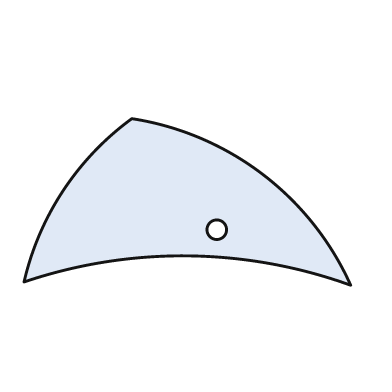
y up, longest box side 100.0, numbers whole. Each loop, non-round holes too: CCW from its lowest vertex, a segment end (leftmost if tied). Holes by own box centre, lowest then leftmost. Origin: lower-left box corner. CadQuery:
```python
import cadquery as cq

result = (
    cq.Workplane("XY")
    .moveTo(100.0, 0.0)
    .threePointArc((73.0, 34.0), (33.0, 51.0))
    .threePointArc((12.0, 29.0), (0.0, 1.0))
    .threePointArc((50.0, 9.0), (100.0, 0.0))
    .close()
    .moveTo(59.0, 17.0)
    .circle(3.0)
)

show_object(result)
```